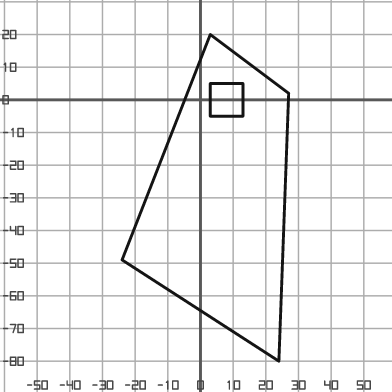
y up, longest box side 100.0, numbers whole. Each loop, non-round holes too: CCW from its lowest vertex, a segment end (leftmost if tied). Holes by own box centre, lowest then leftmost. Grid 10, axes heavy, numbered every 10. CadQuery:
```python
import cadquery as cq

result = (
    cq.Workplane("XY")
    .moveTo(24.0, -80.0)
    .lineTo(27.0, 2.0)
    .lineTo(3.0, 20.0)
    .lineTo(-24.0, -49.0)
    .close()
    .moveTo(3.0, -5.0)
    .lineTo(13.0, -5.0)
    .lineTo(13.0, 5.0)
    .lineTo(3.0, 5.0)
    .close()
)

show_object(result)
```